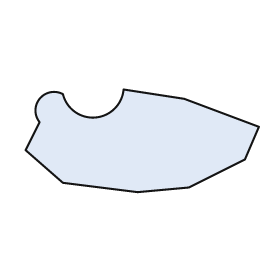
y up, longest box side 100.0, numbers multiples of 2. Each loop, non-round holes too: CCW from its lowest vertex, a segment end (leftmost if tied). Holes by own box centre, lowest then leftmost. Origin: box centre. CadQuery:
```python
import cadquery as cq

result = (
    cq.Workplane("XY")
    .moveTo(-2.0, -22.0)
    .lineTo(20.0, -20.0)
    .lineTo(44.0, -8.0)
    .lineTo(50.0, 6.0)
    .lineTo(18.0, 18.0)
    .lineTo(-8.0, 22.0)
    .threePointArc((-20.0, 10.0), (-34.0, 20.0))
    .threePointArc((-44.0, 18.0), (-44.0, 8.0))
    .lineTo(-50.0, -4.0)
    .lineTo(-34.0, -18.0)
    .close()
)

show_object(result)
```